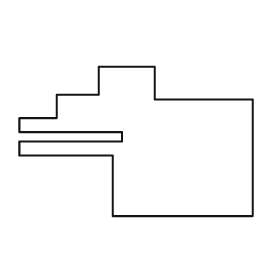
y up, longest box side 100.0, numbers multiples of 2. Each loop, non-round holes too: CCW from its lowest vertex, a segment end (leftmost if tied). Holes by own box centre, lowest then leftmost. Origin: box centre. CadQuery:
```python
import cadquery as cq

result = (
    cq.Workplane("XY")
    .moveTo(-10.0, -32.0)
    .lineTo(50.0, -32.0)
    .lineTo(50.0, 18.0)
    .lineTo(8.0, 18.0)
    .lineTo(8.0, 32.0)
    .lineTo(-16.0, 32.0)
    .lineTo(-16.0, 20.0)
    .lineTo(-34.0, 20.0)
    .lineTo(-34.0, 10.0)
    .lineTo(-50.0, 10.0)
    .lineTo(-50.0, 4.0)
    .lineTo(-6.0, 4.0)
    .lineTo(-6.0, 0.0)
    .lineTo(-50.0, 0.0)
    .lineTo(-50.0, -6.0)
    .lineTo(-10.0, -6.0)
    .close()
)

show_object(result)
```